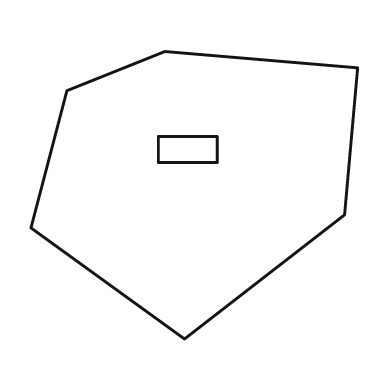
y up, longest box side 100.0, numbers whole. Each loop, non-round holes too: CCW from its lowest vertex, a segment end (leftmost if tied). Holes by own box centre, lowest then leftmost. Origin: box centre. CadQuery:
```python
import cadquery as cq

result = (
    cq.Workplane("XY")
    .moveTo(-3.0, -44.0)
    .lineTo(46.0, -6.0)
    .lineTo(50.0, 39.0)
    .lineTo(-9.0, 44.0)
    .lineTo(-39.0, 32.0)
    .lineTo(-50.0, -10.0)
    .close()
    .moveTo(-11.0, 10.0)
    .lineTo(7.0, 10.0)
    .lineTo(7.0, 18.0)
    .lineTo(-11.0, 18.0)
    .close()
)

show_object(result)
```